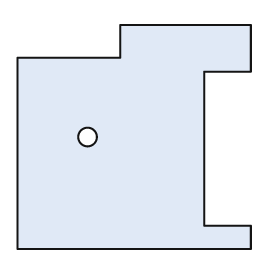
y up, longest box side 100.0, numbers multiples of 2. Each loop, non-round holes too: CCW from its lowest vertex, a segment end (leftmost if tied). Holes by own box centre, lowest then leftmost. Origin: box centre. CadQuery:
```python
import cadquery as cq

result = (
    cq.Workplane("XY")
    .moveTo(-50.0, -48.0)
    .lineTo(50.0, -48.0)
    .lineTo(50.0, -38.0)
    .lineTo(30.0, -38.0)
    .lineTo(30.0, 28.0)
    .lineTo(50.0, 28.0)
    .lineTo(50.0, 48.0)
    .lineTo(-6.0, 48.0)
    .lineTo(-6.0, 34.0)
    .lineTo(-50.0, 34.0)
    .close()
    .moveTo(-20.0, 0.0)
    .circle(4.0)
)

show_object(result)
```